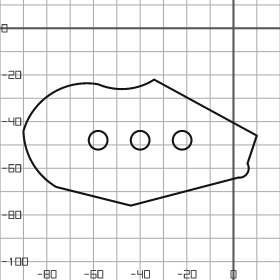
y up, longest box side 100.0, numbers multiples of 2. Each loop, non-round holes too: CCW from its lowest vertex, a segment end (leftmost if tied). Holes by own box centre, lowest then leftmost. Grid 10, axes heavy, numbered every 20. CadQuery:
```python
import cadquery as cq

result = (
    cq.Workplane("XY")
    .moveTo(-44.0, -76.0)
    .lineTo(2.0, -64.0)
    .threePointArc((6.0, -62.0), (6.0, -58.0))
    .lineTo(10.0, -46.0)
    .lineTo(-34.0, -22.0)
    .threePointArc((-46.0, -26.0), (-58.0, -24.0))
    .threePointArc((-78.0, -28.0), (-90.0, -44.0))
    .threePointArc((-86.0, -58.0), (-76.0, -68.0))
    .close()
    .moveTo(-58.0, -48.0)
    .circle(4.0)
    .moveTo(-40.0, -48.0)
    .circle(4.0)
    .moveTo(-22.0, -48.0)
    .circle(4.0)
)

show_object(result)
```